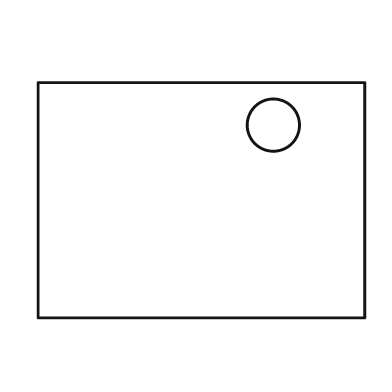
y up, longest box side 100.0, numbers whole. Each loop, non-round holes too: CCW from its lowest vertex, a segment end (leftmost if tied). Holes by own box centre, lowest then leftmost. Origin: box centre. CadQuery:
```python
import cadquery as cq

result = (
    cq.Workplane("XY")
    .moveTo(-50.0, -36.0)
    .lineTo(50.0, -36.0)
    .lineTo(50.0, 36.0)
    .lineTo(-50.0, 36.0)
    .close()
    .moveTo(22.0, 23.0)
    .circle(8.0)
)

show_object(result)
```